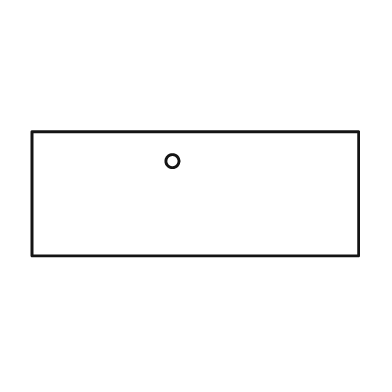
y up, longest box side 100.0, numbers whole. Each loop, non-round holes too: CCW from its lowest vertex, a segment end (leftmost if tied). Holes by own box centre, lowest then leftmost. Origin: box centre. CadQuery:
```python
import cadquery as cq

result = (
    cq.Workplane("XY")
    .moveTo(-50.0, -19.0)
    .lineTo(50.0, -19.0)
    .lineTo(50.0, 19.0)
    .lineTo(-50.0, 19.0)
    .close()
    .moveTo(-7.0, 10.0)
    .circle(2.0)
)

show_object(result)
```